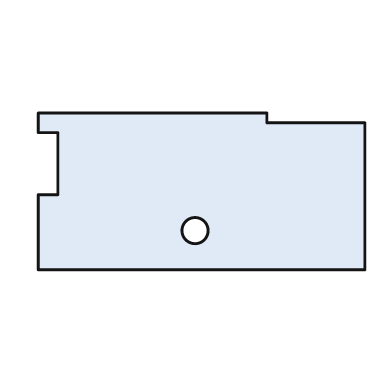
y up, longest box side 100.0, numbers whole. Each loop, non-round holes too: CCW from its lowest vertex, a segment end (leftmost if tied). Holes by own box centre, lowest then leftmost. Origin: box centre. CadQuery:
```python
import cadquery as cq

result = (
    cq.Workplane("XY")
    .moveTo(-50.0, -24.0)
    .lineTo(50.0, -24.0)
    .lineTo(50.0, 21.0)
    .lineTo(20.0, 21.0)
    .lineTo(20.0, 24.0)
    .lineTo(-50.0, 24.0)
    .lineTo(-50.0, 18.0)
    .lineTo(-44.0, 18.0)
    .lineTo(-44.0, -1.0)
    .lineTo(-50.0, -1.0)
    .close()
    .moveTo(-2.0, -12.0)
    .circle(4.0)
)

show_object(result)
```